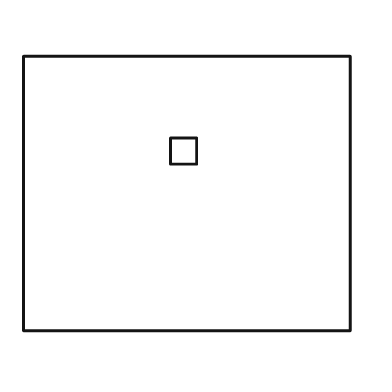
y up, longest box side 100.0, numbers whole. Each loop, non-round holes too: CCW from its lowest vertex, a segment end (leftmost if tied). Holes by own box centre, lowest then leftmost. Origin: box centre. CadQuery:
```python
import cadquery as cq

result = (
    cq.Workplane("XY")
    .moveTo(-50.0, -42.0)
    .lineTo(50.0, -42.0)
    .lineTo(50.0, 42.0)
    .lineTo(-50.0, 42.0)
    .close()
    .moveTo(-5.0, 9.0)
    .lineTo(3.0, 9.0)
    .lineTo(3.0, 17.0)
    .lineTo(-5.0, 17.0)
    .close()
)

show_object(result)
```